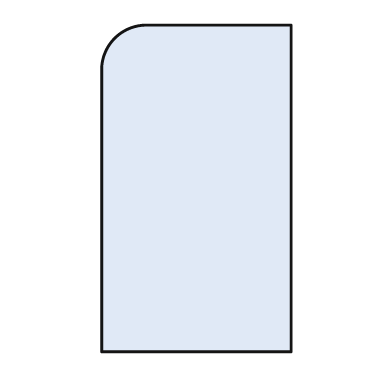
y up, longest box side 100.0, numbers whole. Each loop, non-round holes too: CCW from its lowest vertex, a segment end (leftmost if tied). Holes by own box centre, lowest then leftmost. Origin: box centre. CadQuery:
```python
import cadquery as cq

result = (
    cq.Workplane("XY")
    .moveTo(-29.0, -50.0)
    .lineTo(29.0, -50.0)
    .lineTo(29.0, 50.0)
    .lineTo(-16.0, 50.0)
    .threePointArc((-25.0, 46.0), (-29.0, 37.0))
    .close()
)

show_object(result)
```